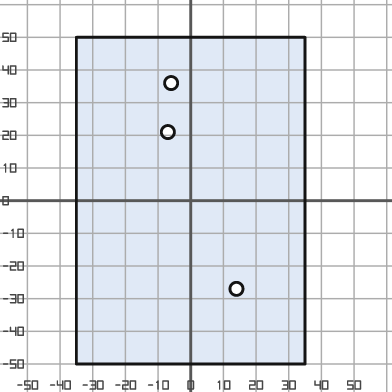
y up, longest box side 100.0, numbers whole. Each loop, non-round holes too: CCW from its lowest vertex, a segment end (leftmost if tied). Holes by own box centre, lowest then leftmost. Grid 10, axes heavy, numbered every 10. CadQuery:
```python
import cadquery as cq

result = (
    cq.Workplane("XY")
    .moveTo(-35.0, -50.0)
    .lineTo(35.0, -50.0)
    .lineTo(35.0, 50.0)
    .lineTo(-35.0, 50.0)
    .close()
    .moveTo(14.0, -27.0)
    .circle(2.0)
    .moveTo(-7.0, 21.0)
    .circle(2.0)
    .moveTo(-6.0, 36.0)
    .circle(2.0)
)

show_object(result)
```